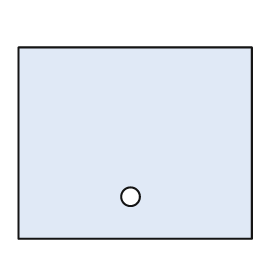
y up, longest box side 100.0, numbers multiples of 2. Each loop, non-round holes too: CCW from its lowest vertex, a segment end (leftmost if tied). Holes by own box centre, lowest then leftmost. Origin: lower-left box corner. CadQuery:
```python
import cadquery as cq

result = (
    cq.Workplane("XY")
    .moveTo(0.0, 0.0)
    .lineTo(100.0, 0.0)
    .lineTo(100.0, 82.0)
    .lineTo(0.0, 82.0)
    .close()
    .moveTo(48.0, 18.0)
    .circle(4.0)
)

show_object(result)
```